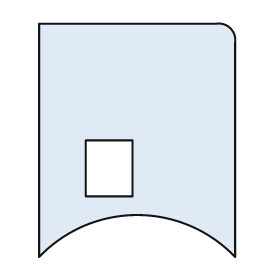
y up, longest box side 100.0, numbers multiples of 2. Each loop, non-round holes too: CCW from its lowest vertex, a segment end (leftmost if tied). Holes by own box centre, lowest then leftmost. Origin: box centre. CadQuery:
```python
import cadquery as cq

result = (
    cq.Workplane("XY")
    .moveTo(-42.0, -50.0)
    .threePointArc((0.0, -32.0), (42.0, -50.0))
    .lineTo(42.0, 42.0)
    .threePointArc((40.0, 48.0), (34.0, 50.0))
    .lineTo(-42.0, 50.0)
    .close()
    .moveTo(-22.0, -24.0)
    .lineTo(-2.0, -24.0)
    .lineTo(-2.0, 0.0)
    .lineTo(-22.0, 0.0)
    .close()
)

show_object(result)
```